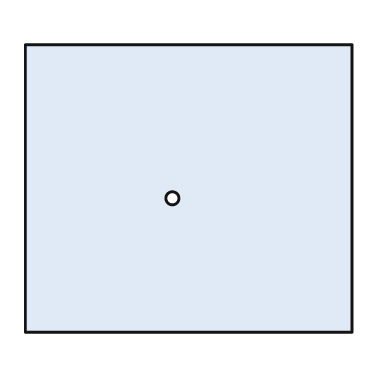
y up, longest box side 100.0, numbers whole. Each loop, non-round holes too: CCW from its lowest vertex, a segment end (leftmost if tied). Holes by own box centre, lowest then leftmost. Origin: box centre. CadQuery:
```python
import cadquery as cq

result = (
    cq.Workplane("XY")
    .moveTo(-50.0, -44.0)
    .lineTo(50.0, -44.0)
    .lineTo(50.0, 44.0)
    .lineTo(-50.0, 44.0)
    .close()
    .moveTo(-5.0, -3.0)
    .circle(2.0)
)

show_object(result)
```